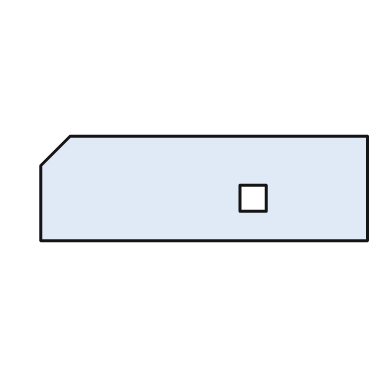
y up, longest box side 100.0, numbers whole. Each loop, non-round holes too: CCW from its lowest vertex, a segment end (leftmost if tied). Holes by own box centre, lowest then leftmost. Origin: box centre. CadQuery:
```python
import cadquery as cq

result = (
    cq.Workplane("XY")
    .moveTo(-50.0, -16.0)
    .lineTo(50.0, -16.0)
    .lineTo(50.0, 16.0)
    .lineTo(-41.0, 16.0)
    .lineTo(-50.0, 7.0)
    .close()
    .moveTo(11.0, -7.0)
    .lineTo(19.0, -7.0)
    .lineTo(19.0, 1.0)
    .lineTo(11.0, 1.0)
    .close()
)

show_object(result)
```